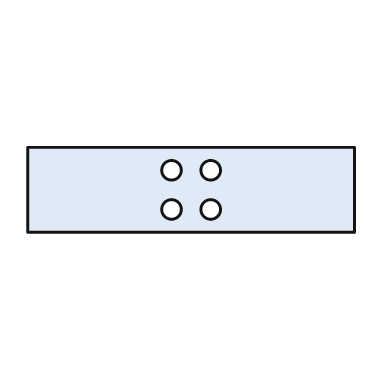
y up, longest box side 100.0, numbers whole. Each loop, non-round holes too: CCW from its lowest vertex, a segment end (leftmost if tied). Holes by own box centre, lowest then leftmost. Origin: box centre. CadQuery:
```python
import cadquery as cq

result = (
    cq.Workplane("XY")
    .moveTo(-50.0, -13.0)
    .lineTo(50.0, -13.0)
    .lineTo(50.0, 13.0)
    .lineTo(-50.0, 13.0)
    .close()
    .moveTo(-6.0, -6.0)
    .circle(3.0)
    .moveTo(6.0, -6.0)
    .circle(3.0)
    .moveTo(-6.0, 6.0)
    .circle(3.0)
    .moveTo(6.0, 6.0)
    .circle(3.0)
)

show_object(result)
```